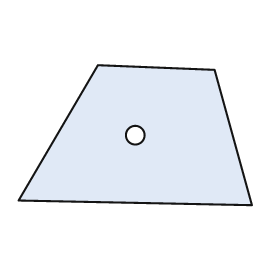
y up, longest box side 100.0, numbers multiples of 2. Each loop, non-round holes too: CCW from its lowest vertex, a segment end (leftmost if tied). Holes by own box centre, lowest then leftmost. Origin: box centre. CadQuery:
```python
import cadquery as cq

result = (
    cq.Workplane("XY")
    .moveTo(50.0, -30.0)
    .lineTo(34.0, 28.0)
    .lineTo(-16.0, 30.0)
    .lineTo(-50.0, -28.0)
    .close()
    .moveTo(0.0, 0.0)
    .circle(4.0)
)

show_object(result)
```